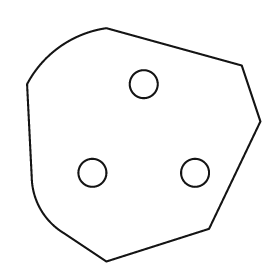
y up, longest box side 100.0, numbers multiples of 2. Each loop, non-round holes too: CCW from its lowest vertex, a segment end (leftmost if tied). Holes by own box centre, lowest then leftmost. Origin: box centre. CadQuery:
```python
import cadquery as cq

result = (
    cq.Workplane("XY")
    .moveTo(-16.0, -50.0)
    .lineTo(28.0, -36.0)
    .lineTo(50.0, 10.0)
    .lineTo(42.0, 34.0)
    .lineTo(-16.0, 50.0)
    .threePointArc((-36.0, 42.0), (-50.0, 26.0))
    .lineTo(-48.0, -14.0)
    .threePointArc((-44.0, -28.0), (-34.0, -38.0))
    .close()
    .moveTo(-22.0, -12.0)
    .circle(6.0)
    .moveTo(22.0, -12.0)
    .circle(6.0)
    .moveTo(0.0, 26.0)
    .circle(6.0)
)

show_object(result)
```